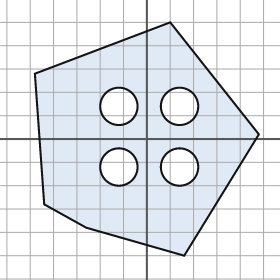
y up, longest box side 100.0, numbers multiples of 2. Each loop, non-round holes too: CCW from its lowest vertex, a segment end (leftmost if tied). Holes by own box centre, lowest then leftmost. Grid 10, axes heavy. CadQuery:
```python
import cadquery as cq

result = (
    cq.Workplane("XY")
    .moveTo(16.0, -50.0)
    .lineTo(48.0, 2.0)
    .lineTo(10.0, 50.0)
    .lineTo(-48.0, 28.0)
    .lineTo(-44.0, -28.0)
    .lineTo(-26.0, -38.0)
    .close()
    .moveTo(-12.0, -12.0)
    .circle(8.0)
    .moveTo(14.0, -12.0)
    .circle(8.0)
    .moveTo(-12.0, 14.0)
    .circle(8.0)
    .moveTo(14.0, 14.0)
    .circle(8.0)
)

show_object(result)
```